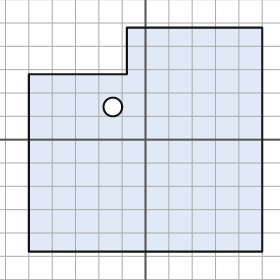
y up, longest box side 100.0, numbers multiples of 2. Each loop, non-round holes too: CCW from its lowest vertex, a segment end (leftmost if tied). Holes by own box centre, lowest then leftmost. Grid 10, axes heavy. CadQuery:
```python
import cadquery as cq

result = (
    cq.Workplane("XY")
    .moveTo(-50.0, -48.0)
    .lineTo(50.0, -48.0)
    .lineTo(50.0, 48.0)
    .lineTo(-8.0, 48.0)
    .lineTo(-8.0, 28.0)
    .lineTo(-50.0, 28.0)
    .close()
    .moveTo(-14.0, 14.0)
    .circle(4.0)
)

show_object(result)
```